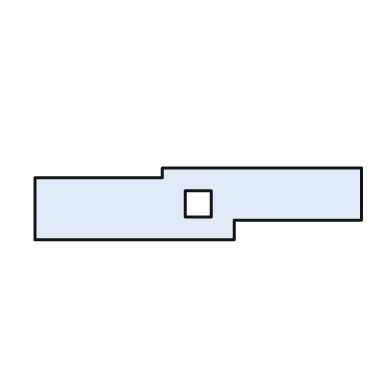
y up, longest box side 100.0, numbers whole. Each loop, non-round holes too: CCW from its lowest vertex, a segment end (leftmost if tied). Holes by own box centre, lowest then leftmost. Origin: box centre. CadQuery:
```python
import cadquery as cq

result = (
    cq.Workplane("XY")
    .moveTo(-50.0, -11.0)
    .lineTo(11.0, -11.0)
    .lineTo(11.0, -5.0)
    .lineTo(50.0, -5.0)
    .lineTo(50.0, 11.0)
    .lineTo(-11.0, 11.0)
    .lineTo(-11.0, 8.0)
    .lineTo(-50.0, 8.0)
    .close()
    .moveTo(-4.0, -4.0)
    .lineTo(4.0, -4.0)
    .lineTo(4.0, 4.0)
    .lineTo(-4.0, 4.0)
    .close()
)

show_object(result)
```